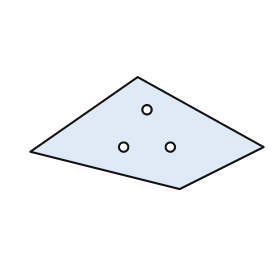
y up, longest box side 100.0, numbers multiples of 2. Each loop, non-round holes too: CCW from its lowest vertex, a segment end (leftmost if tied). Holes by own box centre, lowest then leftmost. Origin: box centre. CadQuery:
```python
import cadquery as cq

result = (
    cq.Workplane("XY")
    .moveTo(14.0, -24.0)
    .lineTo(50.0, -6.0)
    .lineTo(-4.0, 24.0)
    .lineTo(-50.0, -8.0)
    .close()
    .moveTo(-10.0, -6.0)
    .circle(2.0)
    .moveTo(10.0, -6.0)
    .circle(2.0)
    .moveTo(0.0, 10.0)
    .circle(2.0)
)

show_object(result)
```